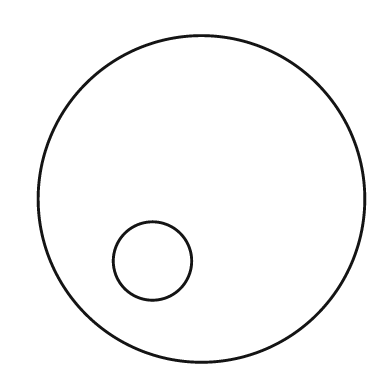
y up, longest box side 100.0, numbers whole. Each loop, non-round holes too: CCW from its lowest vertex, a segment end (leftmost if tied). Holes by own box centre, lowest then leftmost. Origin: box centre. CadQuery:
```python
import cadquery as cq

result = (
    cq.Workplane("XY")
    .moveTo(0.0, 0.0)
    .circle(50.0)
    .moveTo(-15.0, -19.0)
    .circle(12.0)
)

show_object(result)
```